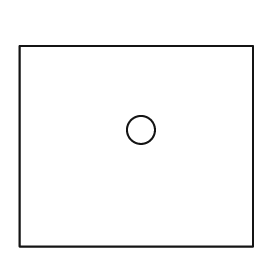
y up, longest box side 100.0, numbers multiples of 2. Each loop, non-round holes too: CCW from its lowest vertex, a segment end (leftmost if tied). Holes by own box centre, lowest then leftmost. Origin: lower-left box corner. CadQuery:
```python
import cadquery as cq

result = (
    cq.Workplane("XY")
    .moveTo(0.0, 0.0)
    .lineTo(100.0, 0.0)
    .lineTo(100.0, 86.0)
    .lineTo(0.0, 86.0)
    .close()
    .moveTo(52.0, 50.0)
    .circle(6.0)
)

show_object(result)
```